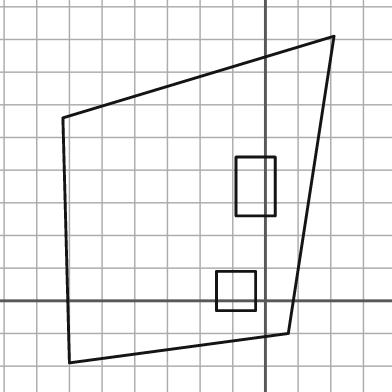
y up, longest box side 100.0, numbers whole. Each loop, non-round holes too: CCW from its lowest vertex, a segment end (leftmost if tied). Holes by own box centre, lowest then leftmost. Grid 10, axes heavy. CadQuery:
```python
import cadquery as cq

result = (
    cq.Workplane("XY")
    .moveTo(-60.0, -19.0)
    .lineTo(7.0, -10.0)
    .lineTo(21.0, 81.0)
    .lineTo(-62.0, 56.0)
    .close()
    .moveTo(-15.0, -3.0)
    .lineTo(-3.0, -3.0)
    .lineTo(-3.0, 9.0)
    .lineTo(-15.0, 9.0)
    .close()
    .moveTo(-9.0, 26.0)
    .lineTo(3.0, 26.0)
    .lineTo(3.0, 44.0)
    .lineTo(-9.0, 44.0)
    .close()
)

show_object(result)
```